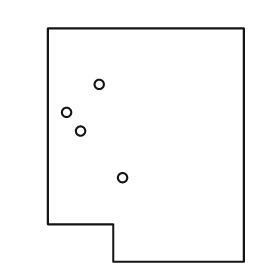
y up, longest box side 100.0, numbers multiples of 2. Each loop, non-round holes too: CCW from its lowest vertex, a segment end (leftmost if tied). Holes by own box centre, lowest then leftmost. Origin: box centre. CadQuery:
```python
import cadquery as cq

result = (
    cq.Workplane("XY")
    .moveTo(-14.0, -50.0)
    .lineTo(42.0, -50.0)
    .lineTo(42.0, 50.0)
    .lineTo(-42.0, 50.0)
    .lineTo(-42.0, -34.0)
    .lineTo(-14.0, -34.0)
    .close()
    .moveTo(-10.0, -14.0)
    .circle(2.0)
    .moveTo(-28.0, 6.0)
    .circle(2.0)
    .moveTo(-34.0, 14.0)
    .circle(2.0)
    .moveTo(-20.0, 26.0)
    .circle(2.0)
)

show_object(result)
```